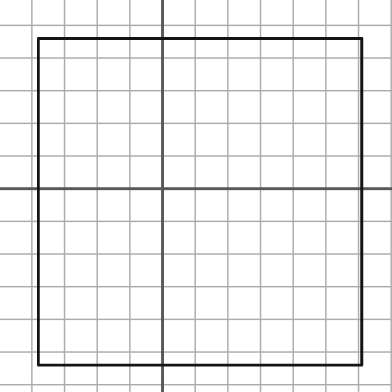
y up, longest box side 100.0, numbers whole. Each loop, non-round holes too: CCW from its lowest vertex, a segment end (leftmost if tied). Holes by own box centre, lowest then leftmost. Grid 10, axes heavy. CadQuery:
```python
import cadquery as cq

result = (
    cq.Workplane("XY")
    .moveTo(-38.0, -54.0)
    .lineTo(61.0, -54.0)
    .lineTo(61.0, 46.0)
    .lineTo(-38.0, 46.0)
    .close()
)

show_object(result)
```